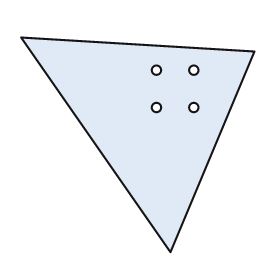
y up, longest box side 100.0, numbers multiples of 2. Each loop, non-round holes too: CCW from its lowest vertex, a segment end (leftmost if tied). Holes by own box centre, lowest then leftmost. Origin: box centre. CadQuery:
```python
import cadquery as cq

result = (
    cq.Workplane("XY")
    .moveTo(14.0, -46.0)
    .lineTo(50.0, 40.0)
    .lineTo(-50.0, 46.0)
    .close()
    .moveTo(8.0, 16.0)
    .circle(2.0)
    .moveTo(24.0, 16.0)
    .circle(2.0)
    .moveTo(8.0, 32.0)
    .circle(2.0)
    .moveTo(24.0, 32.0)
    .circle(2.0)
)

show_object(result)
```